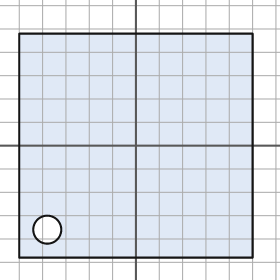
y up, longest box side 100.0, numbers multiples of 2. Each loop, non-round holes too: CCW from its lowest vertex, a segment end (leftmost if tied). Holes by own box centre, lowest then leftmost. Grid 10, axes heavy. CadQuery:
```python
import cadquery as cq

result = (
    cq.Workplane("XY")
    .moveTo(-50.0, -48.0)
    .lineTo(50.0, -48.0)
    .lineTo(50.0, 48.0)
    .lineTo(-50.0, 48.0)
    .close()
    .moveTo(-38.0, -36.0)
    .circle(6.0)
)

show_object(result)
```